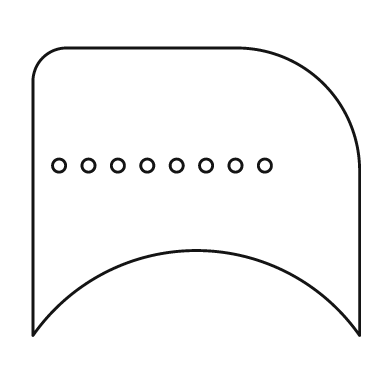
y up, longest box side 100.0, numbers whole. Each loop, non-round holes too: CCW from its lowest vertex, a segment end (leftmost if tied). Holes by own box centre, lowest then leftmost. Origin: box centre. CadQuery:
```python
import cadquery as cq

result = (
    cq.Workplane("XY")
    .moveTo(-50.0, -44.0)
    .threePointArc((0.0, -18.0), (50.0, -44.0))
    .lineTo(50.0, 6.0)
    .threePointArc((39.0, 33.0), (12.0, 44.0))
    .lineTo(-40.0, 44.0)
    .threePointArc((-47.0, 41.0), (-50.0, 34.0))
    .close()
    .moveTo(-42.0, 8.0)
    .circle(2.0)
    .moveTo(-33.0, 8.0)
    .circle(2.0)
    .moveTo(-24.0, 8.0)
    .circle(2.0)
    .moveTo(-15.0, 8.0)
    .circle(2.0)
    .moveTo(-6.0, 8.0)
    .circle(2.0)
    .moveTo(3.0, 8.0)
    .circle(2.0)
    .moveTo(12.0, 8.0)
    .circle(2.0)
    .moveTo(21.0, 8.0)
    .circle(2.0)
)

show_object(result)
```